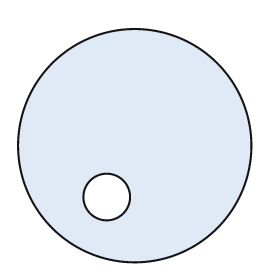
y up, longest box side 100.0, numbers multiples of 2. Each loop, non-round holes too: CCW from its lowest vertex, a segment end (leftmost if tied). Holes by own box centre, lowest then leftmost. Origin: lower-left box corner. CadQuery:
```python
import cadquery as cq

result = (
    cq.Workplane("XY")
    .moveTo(50.0, 50.0)
    .circle(50.0)
    .moveTo(38.0, 28.0)
    .circle(10.0)
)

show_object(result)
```